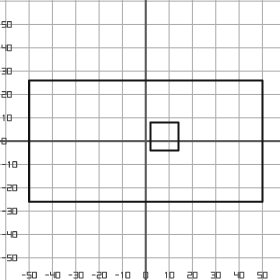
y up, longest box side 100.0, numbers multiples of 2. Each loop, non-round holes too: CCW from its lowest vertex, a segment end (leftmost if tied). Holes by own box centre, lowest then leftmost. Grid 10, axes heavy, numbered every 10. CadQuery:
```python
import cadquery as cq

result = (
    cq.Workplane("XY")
    .moveTo(-50.0, -26.0)
    .lineTo(50.0, -26.0)
    .lineTo(50.0, 26.0)
    .lineTo(-50.0, 26.0)
    .close()
    .moveTo(2.0, -4.0)
    .lineTo(14.0, -4.0)
    .lineTo(14.0, 8.0)
    .lineTo(2.0, 8.0)
    .close()
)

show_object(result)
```